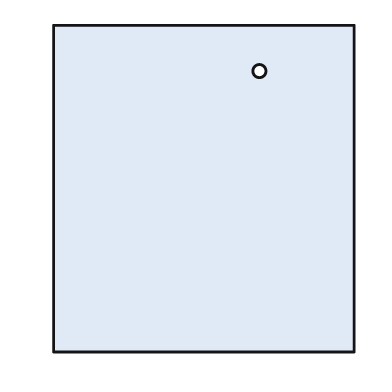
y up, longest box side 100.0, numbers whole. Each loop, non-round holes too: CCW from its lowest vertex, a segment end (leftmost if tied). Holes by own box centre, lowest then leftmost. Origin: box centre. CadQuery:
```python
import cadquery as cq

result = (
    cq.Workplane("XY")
    .moveTo(-46.0, -50.0)
    .lineTo(46.0, -50.0)
    .lineTo(46.0, 50.0)
    .lineTo(-46.0, 50.0)
    .close()
    .moveTo(17.0, 36.0)
    .circle(2.0)
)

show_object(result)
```